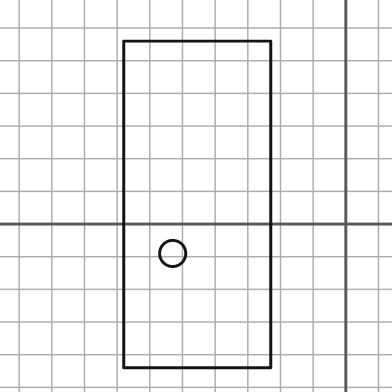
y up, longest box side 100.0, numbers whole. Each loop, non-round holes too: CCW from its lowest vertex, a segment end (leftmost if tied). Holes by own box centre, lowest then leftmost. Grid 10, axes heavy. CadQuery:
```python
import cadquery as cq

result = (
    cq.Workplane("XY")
    .moveTo(-68.0, -44.0)
    .lineTo(-23.0, -44.0)
    .lineTo(-23.0, 56.0)
    .lineTo(-68.0, 56.0)
    .close()
    .moveTo(-53.0, -9.0)
    .circle(4.0)
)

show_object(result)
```